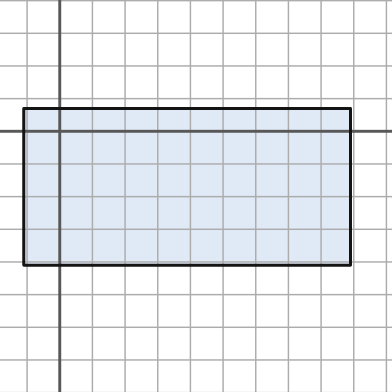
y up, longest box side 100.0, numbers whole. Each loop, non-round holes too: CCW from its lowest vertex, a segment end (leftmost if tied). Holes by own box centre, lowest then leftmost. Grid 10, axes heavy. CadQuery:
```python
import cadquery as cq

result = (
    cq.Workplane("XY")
    .moveTo(-11.0, -41.0)
    .lineTo(89.0, -41.0)
    .lineTo(89.0, 7.0)
    .lineTo(-11.0, 7.0)
    .close()
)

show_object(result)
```